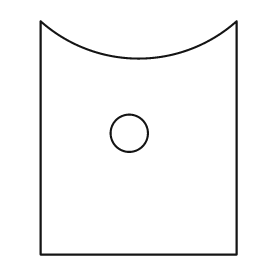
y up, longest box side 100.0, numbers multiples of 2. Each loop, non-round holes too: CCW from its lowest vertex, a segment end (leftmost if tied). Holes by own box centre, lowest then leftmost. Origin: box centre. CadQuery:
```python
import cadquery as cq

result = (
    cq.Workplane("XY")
    .moveTo(-42.0, -50.0)
    .lineTo(42.0, -50.0)
    .lineTo(42.0, 50.0)
    .threePointArc((0.0, 34.0), (-42.0, 50.0))
    .close()
    .moveTo(-4.0, 2.0)
    .circle(8.0)
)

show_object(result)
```